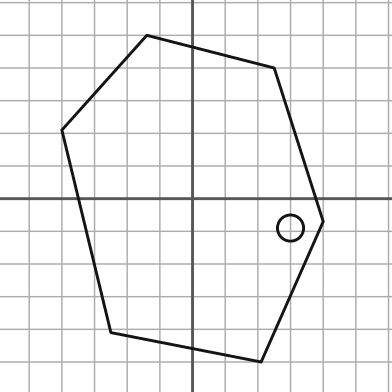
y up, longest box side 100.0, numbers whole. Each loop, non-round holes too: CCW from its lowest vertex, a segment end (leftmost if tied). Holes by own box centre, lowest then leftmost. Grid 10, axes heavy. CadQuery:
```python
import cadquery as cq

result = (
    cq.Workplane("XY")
    .moveTo(21.0, -50.0)
    .lineTo(40.0, -7.0)
    .lineTo(25.0, 40.0)
    .lineTo(-14.0, 50.0)
    .lineTo(-40.0, 21.0)
    .lineTo(-25.0, -41.0)
    .close()
    .moveTo(30.0, -9.0)
    .circle(4.0)
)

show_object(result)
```